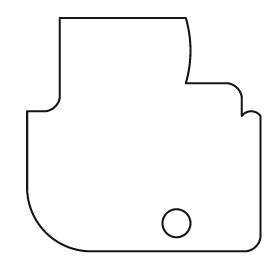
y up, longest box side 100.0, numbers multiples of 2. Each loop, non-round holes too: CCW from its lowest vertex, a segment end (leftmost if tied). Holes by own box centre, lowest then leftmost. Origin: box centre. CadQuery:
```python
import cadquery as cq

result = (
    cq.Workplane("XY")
    .moveTo(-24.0, -50.0)
    .lineTo(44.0, -50.0)
    .threePointArc((48.0, -48.0), (50.0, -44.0))
    .lineTo(50.0, 8.0)
    .threePointArc((46.0, 10.0), (42.0, 8.0))
    .lineTo(42.0, 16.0)
    .threePointArc((40.0, 20.0), (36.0, 22.0))
    .lineTo(18.0, 22.0)
    .threePointArc((20.0, 36.0), (18.0, 50.0))
    .lineTo(-36.0, 50.0)
    .lineTo(-36.0, 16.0)
    .threePointArc((-38.0, 12.0), (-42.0, 10.0))
    .lineTo(-50.0, 10.0)
    .lineTo(-50.0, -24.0)
    .threePointArc((-42.0, -42.0), (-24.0, -50.0))
    .close()
    .moveTo(14.0, -38.0)
    .circle(6.0)
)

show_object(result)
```